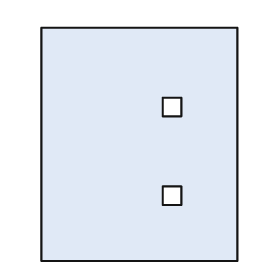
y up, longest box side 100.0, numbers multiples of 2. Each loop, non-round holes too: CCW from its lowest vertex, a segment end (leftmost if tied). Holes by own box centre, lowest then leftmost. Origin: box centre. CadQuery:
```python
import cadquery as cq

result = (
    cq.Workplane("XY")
    .moveTo(-42.0, -50.0)
    .lineTo(42.0, -50.0)
    .lineTo(42.0, 50.0)
    .lineTo(-42.0, 50.0)
    .close()
    .moveTo(10.0, -26.0)
    .lineTo(18.0, -26.0)
    .lineTo(18.0, -18.0)
    .lineTo(10.0, -18.0)
    .close()
    .moveTo(10.0, 12.0)
    .lineTo(18.0, 12.0)
    .lineTo(18.0, 20.0)
    .lineTo(10.0, 20.0)
    .close()
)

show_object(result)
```